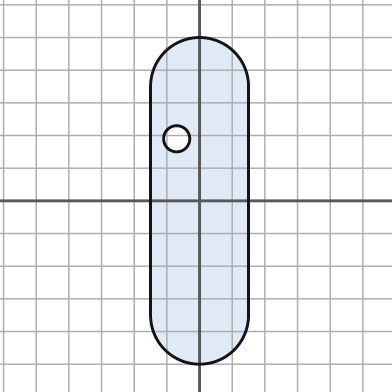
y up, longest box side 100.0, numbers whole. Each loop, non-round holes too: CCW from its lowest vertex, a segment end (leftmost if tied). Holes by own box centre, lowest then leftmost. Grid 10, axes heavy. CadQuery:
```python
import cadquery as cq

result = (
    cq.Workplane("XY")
    .moveTo(-15.0, -35.0)
    .threePointArc((0.0, -50.0), (15.0, -35.0))
    .lineTo(15.0, 35.0)
    .threePointArc((0.0, 50.0), (-15.0, 35.0))
    .close()
    .moveTo(-7.0, 19.0)
    .circle(4.0)
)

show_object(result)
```